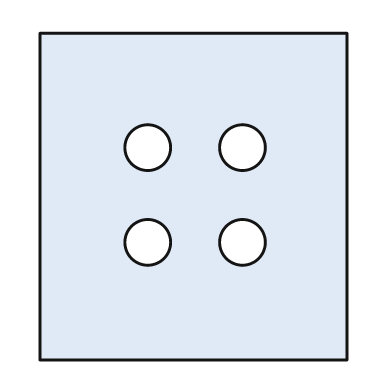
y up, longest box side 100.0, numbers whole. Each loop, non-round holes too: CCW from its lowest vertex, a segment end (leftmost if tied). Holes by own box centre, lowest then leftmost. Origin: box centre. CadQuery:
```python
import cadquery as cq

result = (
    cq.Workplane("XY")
    .moveTo(-47.0, -50.0)
    .lineTo(47.0, -50.0)
    .lineTo(47.0, 50.0)
    .lineTo(-47.0, 50.0)
    .close()
    .moveTo(-14.0, -14.0)
    .circle(7.0)
    .moveTo(15.0, -14.0)
    .circle(7.0)
    .moveTo(-14.0, 15.0)
    .circle(7.0)
    .moveTo(15.0, 15.0)
    .circle(7.0)
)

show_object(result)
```